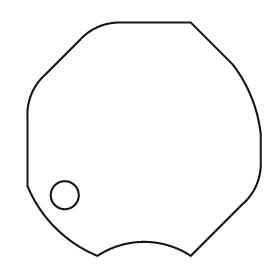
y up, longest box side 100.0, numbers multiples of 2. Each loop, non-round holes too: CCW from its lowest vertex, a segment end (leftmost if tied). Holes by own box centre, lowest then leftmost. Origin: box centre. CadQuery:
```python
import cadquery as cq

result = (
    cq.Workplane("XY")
    .moveTo(-20.0, -50.0)
    .threePointArc((0.0, -44.0), (20.0, -50.0))
    .lineTo(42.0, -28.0)
    .threePointArc((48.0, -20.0), (50.0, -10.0))
    .lineTo(50.0, 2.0)
    .threePointArc((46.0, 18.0), (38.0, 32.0))
    .lineTo(20.0, 50.0)
    .lineTo(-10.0, 50.0)
    .threePointArc((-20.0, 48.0), (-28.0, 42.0))
    .lineTo(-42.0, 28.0)
    .threePointArc((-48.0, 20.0), (-50.0, 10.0))
    .lineTo(-50.0, -20.0)
    .threePointArc((-38.0, -38.0), (-20.0, -50.0))
    .close()
    .moveTo(-34.0, -24.0)
    .circle(6.0)
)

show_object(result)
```